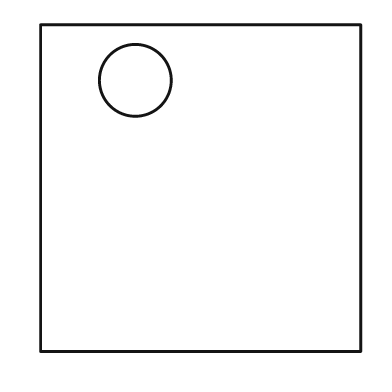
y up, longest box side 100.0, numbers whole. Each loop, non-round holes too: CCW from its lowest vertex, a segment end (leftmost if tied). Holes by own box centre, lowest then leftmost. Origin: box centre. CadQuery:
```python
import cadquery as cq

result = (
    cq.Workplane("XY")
    .moveTo(-49.0, -50.0)
    .lineTo(49.0, -50.0)
    .lineTo(49.0, 50.0)
    .lineTo(-49.0, 50.0)
    .close()
    .moveTo(-20.0, 33.0)
    .circle(11.0)
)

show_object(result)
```